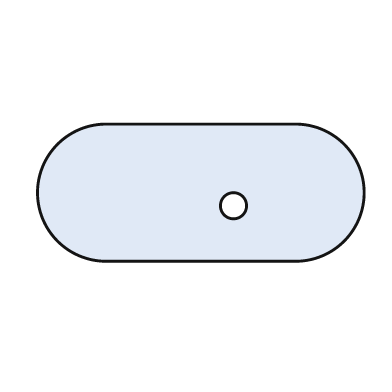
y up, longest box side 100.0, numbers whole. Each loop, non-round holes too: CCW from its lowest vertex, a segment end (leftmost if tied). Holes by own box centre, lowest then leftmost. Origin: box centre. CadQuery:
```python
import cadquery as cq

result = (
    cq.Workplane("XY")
    .moveTo(-29.0, -21.0)
    .lineTo(29.0, -21.0)
    .threePointArc((50.0, 0.0), (29.0, 21.0))
    .lineTo(-29.0, 21.0)
    .threePointArc((-50.0, 0.0), (-29.0, -21.0))
    .close()
    .moveTo(10.0, -4.0)
    .circle(4.0)
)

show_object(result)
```